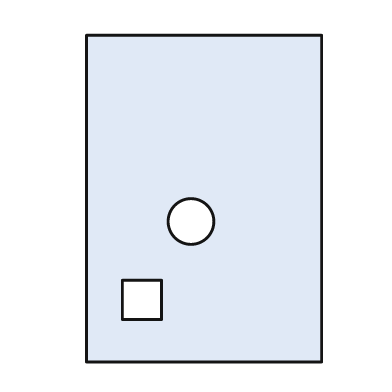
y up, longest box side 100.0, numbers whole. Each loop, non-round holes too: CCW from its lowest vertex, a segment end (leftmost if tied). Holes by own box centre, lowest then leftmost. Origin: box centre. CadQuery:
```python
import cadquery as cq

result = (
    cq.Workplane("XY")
    .moveTo(-36.0, -50.0)
    .lineTo(36.0, -50.0)
    .lineTo(36.0, 50.0)
    .lineTo(-36.0, 50.0)
    .close()
    .moveTo(-25.0, -37.0)
    .lineTo(-13.0, -37.0)
    .lineTo(-13.0, -25.0)
    .lineTo(-25.0, -25.0)
    .close()
    .moveTo(-4.0, -7.0)
    .circle(7.0)
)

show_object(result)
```